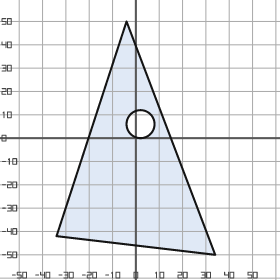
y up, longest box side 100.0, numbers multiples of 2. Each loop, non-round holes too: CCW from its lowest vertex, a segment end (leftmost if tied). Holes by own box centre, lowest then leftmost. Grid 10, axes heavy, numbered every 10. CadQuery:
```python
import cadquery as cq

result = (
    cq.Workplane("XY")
    .moveTo(34.0, -50.0)
    .lineTo(-4.0, 50.0)
    .lineTo(-34.0, -42.0)
    .close()
    .moveTo(2.0, 6.0)
    .circle(6.0)
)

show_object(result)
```